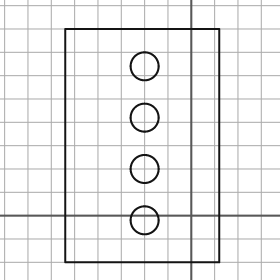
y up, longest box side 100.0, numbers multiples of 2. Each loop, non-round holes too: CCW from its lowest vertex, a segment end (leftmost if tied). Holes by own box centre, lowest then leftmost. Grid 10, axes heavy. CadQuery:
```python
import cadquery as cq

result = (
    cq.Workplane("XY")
    .moveTo(-54.0, -20.0)
    .lineTo(12.0, -20.0)
    .lineTo(12.0, 80.0)
    .lineTo(-54.0, 80.0)
    .close()
    .moveTo(-20.0, -2.0)
    .circle(6.0)
    .moveTo(-20.0, 20.0)
    .circle(6.0)
    .moveTo(-20.0, 42.0)
    .circle(6.0)
    .moveTo(-20.0, 64.0)
    .circle(6.0)
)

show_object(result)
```